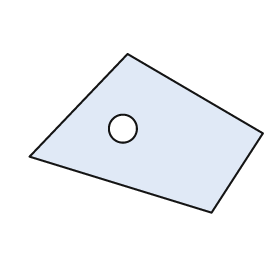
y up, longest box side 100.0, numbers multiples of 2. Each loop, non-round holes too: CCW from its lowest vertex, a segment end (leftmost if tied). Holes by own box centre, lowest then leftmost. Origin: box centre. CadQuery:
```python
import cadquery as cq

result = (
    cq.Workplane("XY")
    .moveTo(28.0, -34.0)
    .lineTo(50.0, 0.0)
    .lineTo(-8.0, 34.0)
    .lineTo(-50.0, -10.0)
    .close()
    .moveTo(-10.0, 2.0)
    .circle(6.0)
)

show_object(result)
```